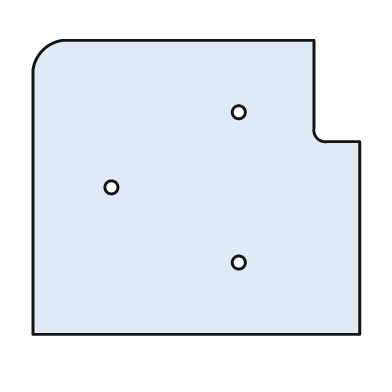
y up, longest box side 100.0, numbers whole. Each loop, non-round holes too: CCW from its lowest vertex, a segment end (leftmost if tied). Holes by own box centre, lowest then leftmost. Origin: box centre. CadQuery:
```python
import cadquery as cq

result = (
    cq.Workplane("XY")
    .moveTo(-50.0, -45.0)
    .lineTo(50.0, -45.0)
    .lineTo(50.0, 14.0)
    .lineTo(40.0, 14.0)
    .threePointArc((37.0, 15.0), (36.0, 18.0))
    .lineTo(36.0, 45.0)
    .lineTo(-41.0, 45.0)
    .threePointArc((-47.0, 42.0), (-50.0, 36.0))
    .close()
    .moveTo(13.0, -23.0)
    .circle(2.0)
    .moveTo(-26.0, 0.0)
    .circle(2.0)
    .moveTo(13.0, 23.0)
    .circle(2.0)
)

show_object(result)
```